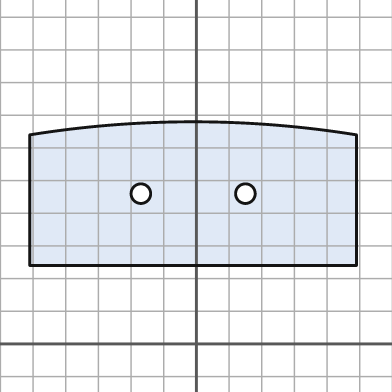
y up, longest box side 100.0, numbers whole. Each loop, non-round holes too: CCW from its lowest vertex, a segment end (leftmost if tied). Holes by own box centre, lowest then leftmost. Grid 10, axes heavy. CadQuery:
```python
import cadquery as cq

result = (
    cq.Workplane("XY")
    .moveTo(-51.0, 24.0)
    .lineTo(49.0, 24.0)
    .lineTo(49.0, 64.0)
    .threePointArc((-1.0, 68.0), (-51.0, 64.0))
    .close()
    .moveTo(-17.0, 46.0)
    .circle(3.0)
    .moveTo(15.0, 46.0)
    .circle(3.0)
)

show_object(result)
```